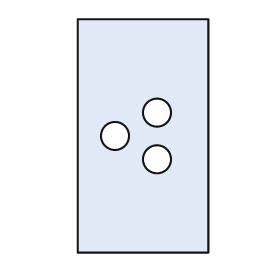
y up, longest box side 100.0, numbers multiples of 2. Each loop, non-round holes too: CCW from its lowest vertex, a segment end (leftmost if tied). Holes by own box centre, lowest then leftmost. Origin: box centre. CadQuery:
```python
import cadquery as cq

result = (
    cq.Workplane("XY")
    .moveTo(-28.0, -50.0)
    .lineTo(28.0, -50.0)
    .lineTo(28.0, 50.0)
    .lineTo(-28.0, 50.0)
    .close()
    .moveTo(6.0, -10.0)
    .circle(6.0)
    .moveTo(-12.0, 0.0)
    .circle(6.0)
    .moveTo(6.0, 10.0)
    .circle(6.0)
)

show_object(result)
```